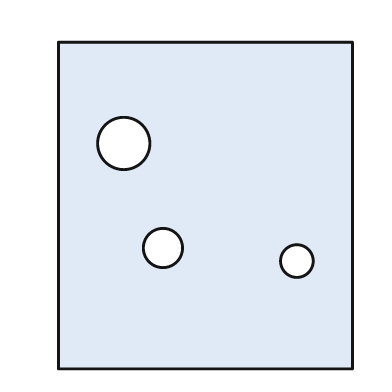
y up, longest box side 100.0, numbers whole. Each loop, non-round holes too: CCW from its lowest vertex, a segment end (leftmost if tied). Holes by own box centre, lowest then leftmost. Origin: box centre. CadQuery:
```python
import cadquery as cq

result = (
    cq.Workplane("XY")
    .moveTo(-45.0, -50.0)
    .lineTo(45.0, -50.0)
    .lineTo(45.0, 50.0)
    .lineTo(-45.0, 50.0)
    .close()
    .moveTo(28.0, -17.0)
    .circle(5.0)
    .moveTo(-13.0, -13.0)
    .circle(6.0)
    .moveTo(-25.0, 19.0)
    .circle(8.0)
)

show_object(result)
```